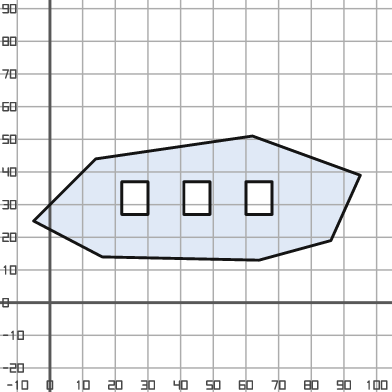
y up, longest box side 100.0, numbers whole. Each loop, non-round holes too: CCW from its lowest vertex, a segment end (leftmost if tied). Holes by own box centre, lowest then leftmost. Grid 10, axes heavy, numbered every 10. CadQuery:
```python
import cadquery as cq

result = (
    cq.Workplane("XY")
    .moveTo(64.0, 13.0)
    .lineTo(86.0, 19.0)
    .lineTo(95.0, 39.0)
    .lineTo(62.0, 51.0)
    .lineTo(14.0, 44.0)
    .lineTo(-5.0, 25.0)
    .lineTo(16.0, 14.0)
    .close()
    .moveTo(22.0, 27.0)
    .lineTo(30.0, 27.0)
    .lineTo(30.0, 37.0)
    .lineTo(22.0, 37.0)
    .close()
    .moveTo(41.0, 27.0)
    .lineTo(49.0, 27.0)
    .lineTo(49.0, 37.0)
    .lineTo(41.0, 37.0)
    .close()
    .moveTo(60.0, 27.0)
    .lineTo(68.0, 27.0)
    .lineTo(68.0, 37.0)
    .lineTo(60.0, 37.0)
    .close()
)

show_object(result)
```